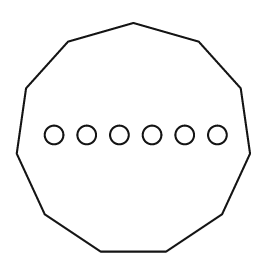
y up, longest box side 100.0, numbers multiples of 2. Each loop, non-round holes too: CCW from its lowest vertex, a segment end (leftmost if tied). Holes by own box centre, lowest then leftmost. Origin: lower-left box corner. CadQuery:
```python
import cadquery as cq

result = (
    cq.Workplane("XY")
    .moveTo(36.0, 0.0)
    .lineTo(64.0, 0.0)
    .lineTo(88.0, 16.0)
    .lineTo(100.0, 42.0)
    .lineTo(96.0, 70.0)
    .lineTo(78.0, 90.0)
    .lineTo(50.0, 98.0)
    .lineTo(22.0, 90.0)
    .lineTo(4.0, 70.0)
    .lineTo(0.0, 42.0)
    .lineTo(12.0, 16.0)
    .close()
    .moveTo(16.0, 50.0)
    .circle(4.0)
    .moveTo(30.0, 50.0)
    .circle(4.0)
    .moveTo(44.0, 50.0)
    .circle(4.0)
    .moveTo(58.0, 50.0)
    .circle(4.0)
    .moveTo(72.0, 50.0)
    .circle(4.0)
    .moveTo(86.0, 50.0)
    .circle(4.0)
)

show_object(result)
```